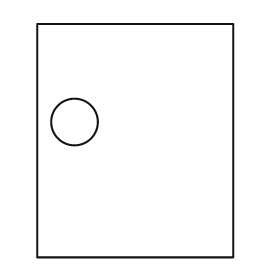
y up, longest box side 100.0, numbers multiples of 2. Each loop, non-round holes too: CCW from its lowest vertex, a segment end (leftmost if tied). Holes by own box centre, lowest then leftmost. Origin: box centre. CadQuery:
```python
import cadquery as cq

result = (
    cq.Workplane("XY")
    .moveTo(-42.0, -50.0)
    .lineTo(42.0, -50.0)
    .lineTo(42.0, 50.0)
    .lineTo(-42.0, 50.0)
    .close()
    .moveTo(-26.0, 8.0)
    .circle(10.0)
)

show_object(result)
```